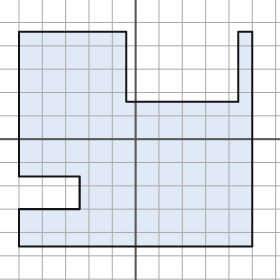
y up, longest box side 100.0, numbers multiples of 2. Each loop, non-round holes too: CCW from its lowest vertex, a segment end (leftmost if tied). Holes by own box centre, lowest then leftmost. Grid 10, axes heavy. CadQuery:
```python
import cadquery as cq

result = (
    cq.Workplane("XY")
    .moveTo(-50.0, -46.0)
    .lineTo(50.0, -46.0)
    .lineTo(50.0, 46.0)
    .lineTo(44.0, 46.0)
    .lineTo(44.0, 16.0)
    .lineTo(-4.0, 16.0)
    .lineTo(-4.0, 46.0)
    .lineTo(-50.0, 46.0)
    .lineTo(-50.0, -16.0)
    .lineTo(-24.0, -16.0)
    .lineTo(-24.0, -30.0)
    .lineTo(-50.0, -30.0)
    .close()
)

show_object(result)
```